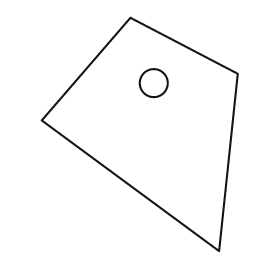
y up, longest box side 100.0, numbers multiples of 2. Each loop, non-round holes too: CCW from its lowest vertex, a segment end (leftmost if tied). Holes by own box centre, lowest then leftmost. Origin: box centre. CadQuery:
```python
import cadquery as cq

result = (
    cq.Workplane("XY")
    .moveTo(34.0, -50.0)
    .lineTo(42.0, 26.0)
    .lineTo(-4.0, 50.0)
    .lineTo(-42.0, 6.0)
    .close()
    .moveTo(6.0, 22.0)
    .circle(6.0)
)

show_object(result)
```